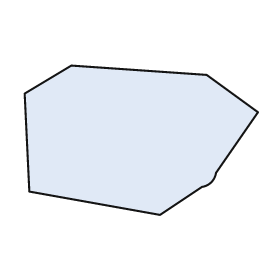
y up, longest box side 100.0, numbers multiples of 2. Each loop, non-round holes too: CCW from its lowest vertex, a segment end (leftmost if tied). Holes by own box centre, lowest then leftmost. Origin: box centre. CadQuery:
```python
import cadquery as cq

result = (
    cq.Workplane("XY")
    .moveTo(8.0, -32.0)
    .lineTo(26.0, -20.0)
    .threePointArc((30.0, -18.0), (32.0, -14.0))
    .lineTo(50.0, 12.0)
    .lineTo(28.0, 28.0)
    .lineTo(-30.0, 32.0)
    .lineTo(-50.0, 20.0)
    .lineTo(-48.0, -22.0)
    .close()
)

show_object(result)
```